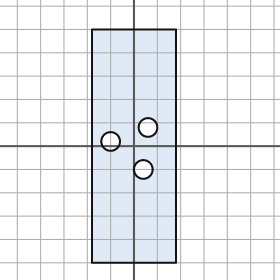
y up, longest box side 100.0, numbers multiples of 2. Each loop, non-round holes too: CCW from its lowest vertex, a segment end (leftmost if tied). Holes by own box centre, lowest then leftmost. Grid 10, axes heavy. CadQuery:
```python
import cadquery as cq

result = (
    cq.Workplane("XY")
    .moveTo(-18.0, -50.0)
    .lineTo(18.0, -50.0)
    .lineTo(18.0, 50.0)
    .lineTo(-18.0, 50.0)
    .close()
    .moveTo(4.0, -10.0)
    .circle(4.0)
    .moveTo(-10.0, 2.0)
    .circle(4.0)
    .moveTo(6.0, 8.0)
    .circle(4.0)
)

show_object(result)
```